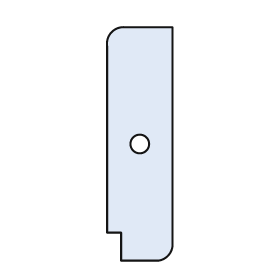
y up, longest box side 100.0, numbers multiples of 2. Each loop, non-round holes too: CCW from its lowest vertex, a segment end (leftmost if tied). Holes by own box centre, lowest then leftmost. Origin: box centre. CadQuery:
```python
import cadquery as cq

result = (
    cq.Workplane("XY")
    .moveTo(-8.0, -50.0)
    .lineTo(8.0, -50.0)
    .threePointArc((12.0, -48.0), (14.0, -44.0))
    .lineTo(14.0, 50.0)
    .lineTo(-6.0, 50.0)
    .threePointArc((-12.0, 48.0), (-14.0, 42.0))
    .lineTo(-14.0, -38.0)
    .lineTo(-8.0, -38.0)
    .close()
    .moveTo(0.0, 0.0)
    .circle(4.0)
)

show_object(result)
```